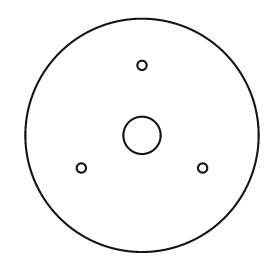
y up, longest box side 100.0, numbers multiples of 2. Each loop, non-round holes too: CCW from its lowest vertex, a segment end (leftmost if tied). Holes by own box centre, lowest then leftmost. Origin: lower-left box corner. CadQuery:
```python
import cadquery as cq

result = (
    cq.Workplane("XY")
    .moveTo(50.0, 50.0)
    .circle(50.0)
    .moveTo(24.0, 36.0)
    .circle(2.0)
    .moveTo(76.0, 36.0)
    .circle(2.0)
    .moveTo(50.0, 50.0)
    .circle(8.0)
    .moveTo(50.0, 80.0)
    .circle(2.0)
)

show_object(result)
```